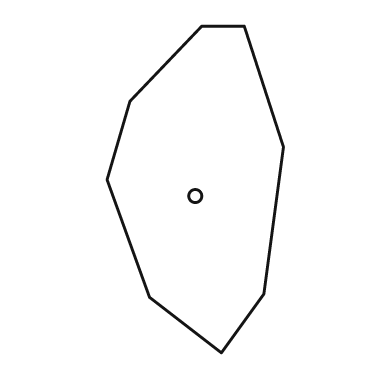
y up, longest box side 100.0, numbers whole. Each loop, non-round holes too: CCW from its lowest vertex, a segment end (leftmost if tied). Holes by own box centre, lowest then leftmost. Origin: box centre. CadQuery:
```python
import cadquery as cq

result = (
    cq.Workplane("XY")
    .moveTo(8.0, -50.0)
    .lineTo(21.0, -32.0)
    .lineTo(27.0, 13.0)
    .lineTo(15.0, 50.0)
    .lineTo(2.0, 50.0)
    .lineTo(-20.0, 27.0)
    .lineTo(-27.0, 3.0)
    .lineTo(-14.0, -33.0)
    .close()
    .moveTo(0.0, -2.0)
    .circle(2.0)
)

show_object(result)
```